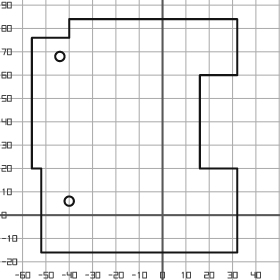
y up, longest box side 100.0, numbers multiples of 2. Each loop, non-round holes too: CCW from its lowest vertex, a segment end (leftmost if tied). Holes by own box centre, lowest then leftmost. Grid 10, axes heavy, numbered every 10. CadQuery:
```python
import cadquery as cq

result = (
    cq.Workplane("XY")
    .moveTo(-52.0, -16.0)
    .lineTo(32.0, -16.0)
    .lineTo(32.0, 20.0)
    .lineTo(16.0, 20.0)
    .lineTo(16.0, 60.0)
    .lineTo(32.0, 60.0)
    .lineTo(32.0, 84.0)
    .lineTo(-40.0, 84.0)
    .lineTo(-40.0, 76.0)
    .lineTo(-56.0, 76.0)
    .lineTo(-56.0, 20.0)
    .lineTo(-52.0, 20.0)
    .close()
    .moveTo(-40.0, 6.0)
    .circle(2.0)
    .moveTo(-44.0, 68.0)
    .circle(2.0)
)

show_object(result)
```